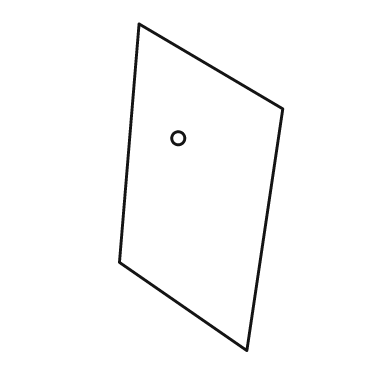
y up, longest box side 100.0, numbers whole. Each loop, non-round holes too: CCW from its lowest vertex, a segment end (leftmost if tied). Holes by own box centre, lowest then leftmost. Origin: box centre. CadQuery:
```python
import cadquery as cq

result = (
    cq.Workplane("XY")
    .moveTo(14.0, -50.0)
    .lineTo(25.0, 24.0)
    .lineTo(-19.0, 50.0)
    .lineTo(-25.0, -23.0)
    .close()
    .moveTo(-7.0, 15.0)
    .circle(2.0)
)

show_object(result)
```